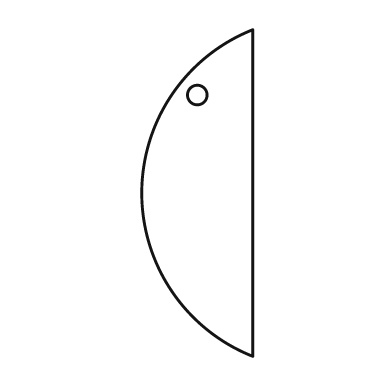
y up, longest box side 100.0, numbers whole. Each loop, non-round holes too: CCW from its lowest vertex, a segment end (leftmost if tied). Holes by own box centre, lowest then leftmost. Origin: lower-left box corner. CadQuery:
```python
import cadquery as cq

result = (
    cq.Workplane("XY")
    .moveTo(34.0, 0.0)
    .lineTo(34.0, 100.0)
    .threePointArc((0.0, 50.0), (34.0, 0.0))
    .close()
    .moveTo(17.0, 80.0)
    .circle(3.0)
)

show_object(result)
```